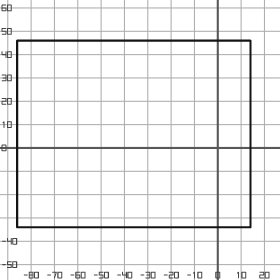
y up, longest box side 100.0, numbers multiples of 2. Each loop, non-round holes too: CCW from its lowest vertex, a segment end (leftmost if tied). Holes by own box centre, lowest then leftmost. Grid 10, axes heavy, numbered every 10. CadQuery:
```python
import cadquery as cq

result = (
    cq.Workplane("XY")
    .moveTo(-86.0, -34.0)
    .lineTo(14.0, -34.0)
    .lineTo(14.0, 46.0)
    .lineTo(-86.0, 46.0)
    .close()
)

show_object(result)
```